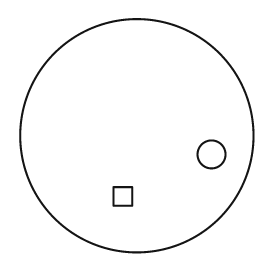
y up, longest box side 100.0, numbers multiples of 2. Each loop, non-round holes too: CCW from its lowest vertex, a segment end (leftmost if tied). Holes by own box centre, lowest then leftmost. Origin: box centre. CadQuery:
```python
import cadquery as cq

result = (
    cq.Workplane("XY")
    .moveTo(0.0, 0.0)
    .circle(50.0)
    .moveTo(-10.0, -30.0)
    .lineTo(-2.0, -30.0)
    .lineTo(-2.0, -22.0)
    .lineTo(-10.0, -22.0)
    .close()
    .moveTo(32.0, -8.0)
    .circle(6.0)
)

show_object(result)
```